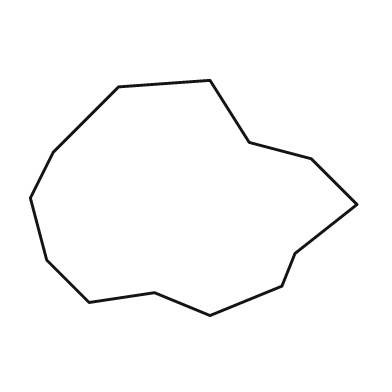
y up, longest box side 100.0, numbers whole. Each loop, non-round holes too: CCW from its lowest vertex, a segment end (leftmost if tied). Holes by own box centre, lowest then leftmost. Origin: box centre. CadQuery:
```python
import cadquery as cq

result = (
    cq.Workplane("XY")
    .moveTo(5.0, -36.0)
    .lineTo(27.0, -27.0)
    .lineTo(31.0, -17.0)
    .lineTo(50.0, -2.0)
    .lineTo(36.0, 12.0)
    .lineTo(17.0, 17.0)
    .lineTo(5.0, 36.0)
    .lineTo(-23.0, 34.0)
    .lineTo(-43.0, 14.0)
    .lineTo(-50.0, 0.0)
    .lineTo(-45.0, -19.0)
    .lineTo(-32.0, -32.0)
    .lineTo(-12.0, -29.0)
    .close()
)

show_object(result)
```